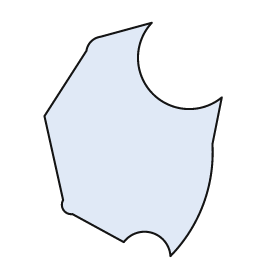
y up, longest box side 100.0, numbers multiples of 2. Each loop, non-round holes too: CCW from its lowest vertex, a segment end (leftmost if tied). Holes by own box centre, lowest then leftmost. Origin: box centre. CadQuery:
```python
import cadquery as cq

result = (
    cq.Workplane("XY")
    .moveTo(16.0, -50.0)
    .threePointArc((30.0, -28.0), (34.0, -2.0))
    .lineTo(38.0, 18.0)
    .threePointArc((8.0, 20.0), (8.0, 50.0))
    .lineTo(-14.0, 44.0)
    .threePointArc((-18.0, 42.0), (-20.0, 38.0))
    .lineTo(-38.0, 10.0)
    .lineTo(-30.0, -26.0)
    .threePointArc((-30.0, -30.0), (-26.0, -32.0))
    .lineTo(-4.0, -44.0)
    .threePointArc((8.0, -40.0), (16.0, -50.0))
    .close()
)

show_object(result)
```